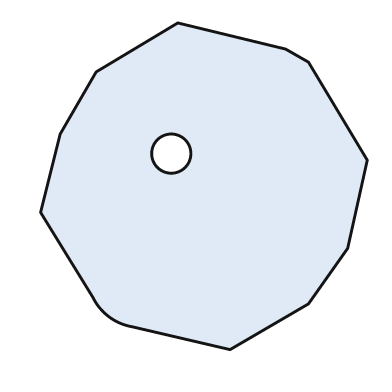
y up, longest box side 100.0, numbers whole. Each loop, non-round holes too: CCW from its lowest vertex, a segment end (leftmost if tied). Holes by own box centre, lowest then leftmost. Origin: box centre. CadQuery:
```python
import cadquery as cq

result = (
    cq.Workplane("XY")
    .moveTo(8.0, -50.0)
    .lineTo(32.0, -36.0)
    .lineTo(44.0, -19.0)
    .lineTo(50.0, 8.0)
    .lineTo(32.0, 38.0)
    .lineTo(25.0, 42.0)
    .lineTo(-8.0, 50.0)
    .lineTo(-33.0, 35.0)
    .lineTo(-44.0, 16.0)
    .lineTo(-50.0, -8.0)
    .lineTo(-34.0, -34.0)
    .threePointArc((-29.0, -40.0), (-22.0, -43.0))
    .close()
    .moveTo(-10.0, 10.0)
    .circle(6.0)
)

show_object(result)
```